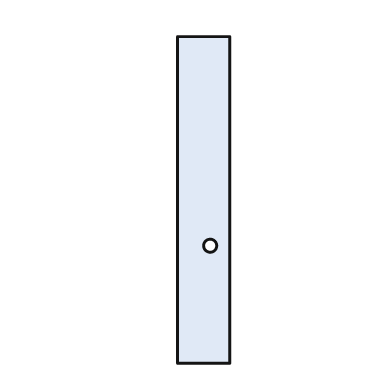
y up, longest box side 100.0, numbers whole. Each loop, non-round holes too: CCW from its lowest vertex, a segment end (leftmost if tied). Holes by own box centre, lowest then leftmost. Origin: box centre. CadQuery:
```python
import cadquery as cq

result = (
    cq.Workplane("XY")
    .moveTo(-8.0, -50.0)
    .lineTo(8.0, -50.0)
    .lineTo(8.0, 50.0)
    .lineTo(-8.0, 50.0)
    .close()
    .moveTo(2.0, -14.0)
    .circle(2.0)
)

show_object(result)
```